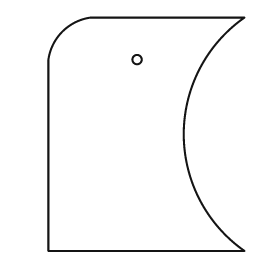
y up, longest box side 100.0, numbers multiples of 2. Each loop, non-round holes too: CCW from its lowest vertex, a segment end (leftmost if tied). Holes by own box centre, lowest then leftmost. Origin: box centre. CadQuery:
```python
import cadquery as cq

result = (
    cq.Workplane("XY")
    .moveTo(-42.0, -50.0)
    .lineTo(42.0, -50.0)
    .threePointArc((16.0, 0.0), (42.0, 50.0))
    .lineTo(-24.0, 50.0)
    .threePointArc((-36.0, 44.0), (-42.0, 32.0))
    .close()
    .moveTo(-4.0, 32.0)
    .circle(2.0)
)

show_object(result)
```